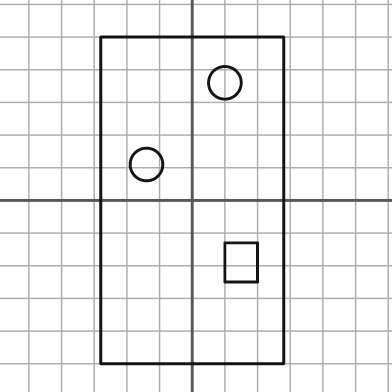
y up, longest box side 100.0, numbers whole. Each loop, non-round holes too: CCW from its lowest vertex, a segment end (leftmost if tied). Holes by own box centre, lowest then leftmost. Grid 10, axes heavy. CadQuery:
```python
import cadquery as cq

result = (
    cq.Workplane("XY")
    .moveTo(-28.0, -50.0)
    .lineTo(28.0, -50.0)
    .lineTo(28.0, 50.0)
    .lineTo(-28.0, 50.0)
    .close()
    .moveTo(10.0, -25.0)
    .lineTo(20.0, -25.0)
    .lineTo(20.0, -13.0)
    .lineTo(10.0, -13.0)
    .close()
    .moveTo(-14.0, 11.0)
    .circle(5.0)
    .moveTo(10.0, 36.0)
    .circle(5.0)
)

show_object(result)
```